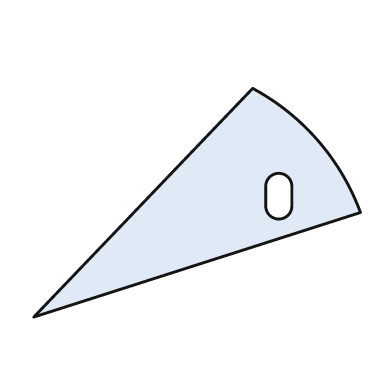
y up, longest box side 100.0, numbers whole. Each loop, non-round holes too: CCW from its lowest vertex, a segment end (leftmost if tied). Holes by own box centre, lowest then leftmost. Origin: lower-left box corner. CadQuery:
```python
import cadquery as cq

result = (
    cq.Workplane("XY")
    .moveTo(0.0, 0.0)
    .lineTo(100.0, 32.0)
    .threePointArc((87.0, 54.0), (67.0, 70.0))
    .close()
    .moveTo(71.0, 34.0)
    .threePointArc((75.0, 30.0), (79.0, 34.0))
    .lineTo(79.0, 40.0)
    .threePointArc((75.0, 44.0), (71.0, 40.0))
    .close()
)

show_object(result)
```